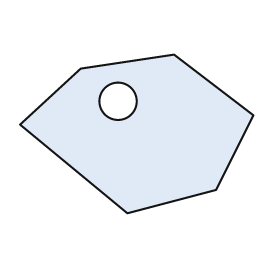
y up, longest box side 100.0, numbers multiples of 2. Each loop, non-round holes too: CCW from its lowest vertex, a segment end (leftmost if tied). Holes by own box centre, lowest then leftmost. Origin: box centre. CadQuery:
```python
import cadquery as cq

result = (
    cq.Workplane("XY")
    .moveTo(-4.0, -34.0)
    .lineTo(34.0, -24.0)
    .lineTo(50.0, 8.0)
    .lineTo(16.0, 34.0)
    .lineTo(-24.0, 28.0)
    .lineTo(-50.0, 4.0)
    .close()
    .moveTo(-8.0, 14.0)
    .circle(8.0)
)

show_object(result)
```